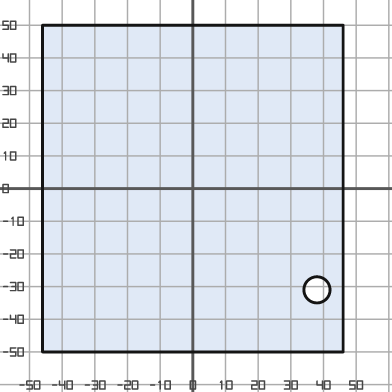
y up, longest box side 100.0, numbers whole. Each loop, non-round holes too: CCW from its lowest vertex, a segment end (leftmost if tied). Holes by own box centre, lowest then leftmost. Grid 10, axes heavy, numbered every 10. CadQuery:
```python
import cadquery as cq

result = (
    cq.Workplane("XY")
    .moveTo(-46.0, -50.0)
    .lineTo(46.0, -50.0)
    .lineTo(46.0, 50.0)
    .lineTo(-46.0, 50.0)
    .close()
    .moveTo(38.0, -31.0)
    .circle(4.0)
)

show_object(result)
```